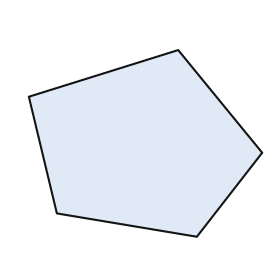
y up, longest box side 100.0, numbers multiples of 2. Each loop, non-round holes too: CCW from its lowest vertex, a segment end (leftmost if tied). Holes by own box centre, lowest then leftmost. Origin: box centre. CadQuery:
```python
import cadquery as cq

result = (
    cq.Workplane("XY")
    .moveTo(22.0, -40.0)
    .lineTo(50.0, -4.0)
    .lineTo(14.0, 40.0)
    .lineTo(-50.0, 20.0)
    .lineTo(-38.0, -30.0)
    .close()
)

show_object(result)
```